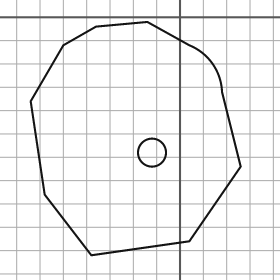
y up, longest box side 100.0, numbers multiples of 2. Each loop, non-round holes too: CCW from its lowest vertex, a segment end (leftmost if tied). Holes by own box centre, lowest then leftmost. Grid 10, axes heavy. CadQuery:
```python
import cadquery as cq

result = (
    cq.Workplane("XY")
    .moveTo(-38.0, -102.0)
    .lineTo(4.0, -96.0)
    .lineTo(26.0, -64.0)
    .lineTo(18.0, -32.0)
    .threePointArc((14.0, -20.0), (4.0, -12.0))
    .lineTo(-14.0, -2.0)
    .lineTo(-36.0, -4.0)
    .lineTo(-50.0, -12.0)
    .lineTo(-64.0, -36.0)
    .lineTo(-58.0, -76.0)
    .close()
    .moveTo(-12.0, -58.0)
    .circle(6.0)
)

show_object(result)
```